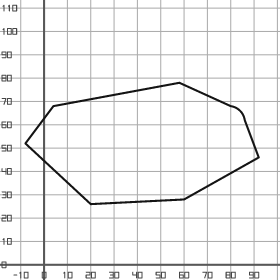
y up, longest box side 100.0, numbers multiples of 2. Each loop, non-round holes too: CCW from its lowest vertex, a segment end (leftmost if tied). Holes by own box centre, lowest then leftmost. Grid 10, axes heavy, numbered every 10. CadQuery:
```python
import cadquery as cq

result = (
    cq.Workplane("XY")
    .moveTo(20.0, 26.0)
    .lineTo(60.0, 28.0)
    .lineTo(92.0, 46.0)
    .lineTo(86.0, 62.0)
    .threePointArc((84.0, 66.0), (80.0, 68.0))
    .lineTo(58.0, 78.0)
    .lineTo(4.0, 68.0)
    .lineTo(-8.0, 52.0)
    .close()
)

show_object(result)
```